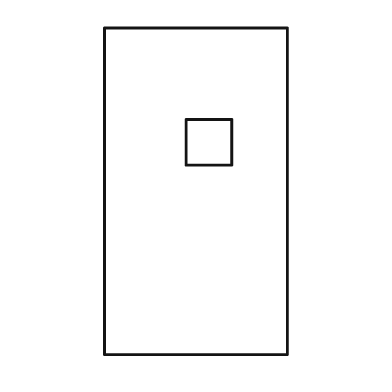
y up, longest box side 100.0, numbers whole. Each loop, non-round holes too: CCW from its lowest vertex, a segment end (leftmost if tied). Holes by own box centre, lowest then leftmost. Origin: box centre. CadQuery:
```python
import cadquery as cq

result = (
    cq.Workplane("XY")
    .moveTo(-28.0, -50.0)
    .lineTo(28.0, -50.0)
    .lineTo(28.0, 50.0)
    .lineTo(-28.0, 50.0)
    .close()
    .moveTo(-3.0, 8.0)
    .lineTo(11.0, 8.0)
    .lineTo(11.0, 22.0)
    .lineTo(-3.0, 22.0)
    .close()
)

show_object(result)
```